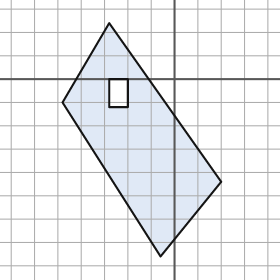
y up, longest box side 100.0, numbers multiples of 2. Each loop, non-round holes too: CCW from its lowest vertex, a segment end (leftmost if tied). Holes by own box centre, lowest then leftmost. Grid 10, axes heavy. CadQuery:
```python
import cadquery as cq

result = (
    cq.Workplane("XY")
    .moveTo(-6.0, -76.0)
    .lineTo(20.0, -44.0)
    .lineTo(-28.0, 24.0)
    .lineTo(-48.0, -10.0)
    .close()
    .moveTo(-28.0, -12.0)
    .lineTo(-20.0, -12.0)
    .lineTo(-20.0, 0.0)
    .lineTo(-28.0, 0.0)
    .close()
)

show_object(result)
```